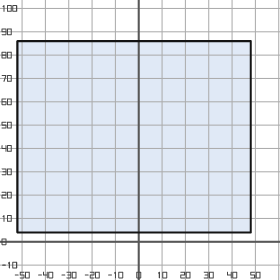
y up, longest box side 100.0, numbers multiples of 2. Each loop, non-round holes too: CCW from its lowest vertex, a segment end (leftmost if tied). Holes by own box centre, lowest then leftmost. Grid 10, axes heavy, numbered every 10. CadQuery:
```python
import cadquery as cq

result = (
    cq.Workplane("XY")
    .moveTo(-52.0, 4.0)
    .lineTo(48.0, 4.0)
    .lineTo(48.0, 86.0)
    .lineTo(-52.0, 86.0)
    .close()
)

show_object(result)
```